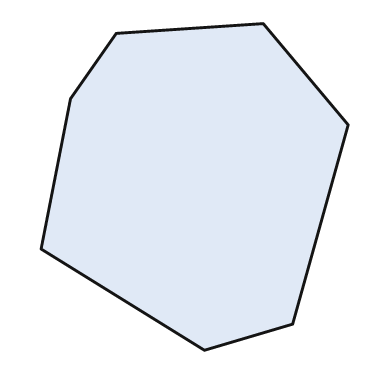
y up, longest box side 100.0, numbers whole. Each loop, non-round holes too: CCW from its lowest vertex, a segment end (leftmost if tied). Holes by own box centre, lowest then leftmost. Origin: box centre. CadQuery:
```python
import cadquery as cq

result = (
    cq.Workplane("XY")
    .moveTo(3.0, -50.0)
    .lineTo(30.0, -42.0)
    .lineTo(47.0, 19.0)
    .lineTo(21.0, 50.0)
    .lineTo(-24.0, 47.0)
    .lineTo(-38.0, 27.0)
    .lineTo(-47.0, -19.0)
    .close()
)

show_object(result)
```